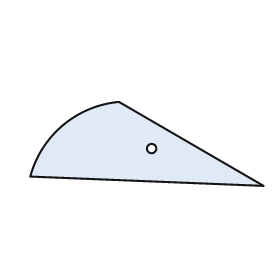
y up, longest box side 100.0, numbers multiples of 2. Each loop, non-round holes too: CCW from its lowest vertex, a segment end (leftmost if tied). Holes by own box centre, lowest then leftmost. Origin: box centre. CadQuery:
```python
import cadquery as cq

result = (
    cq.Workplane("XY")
    .moveTo(50.0, -18.0)
    .lineTo(-12.0, 18.0)
    .threePointArc((-36.0, 8.0), (-50.0, -14.0))
    .close()
    .moveTo(2.0, -2.0)
    .circle(2.0)
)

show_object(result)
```